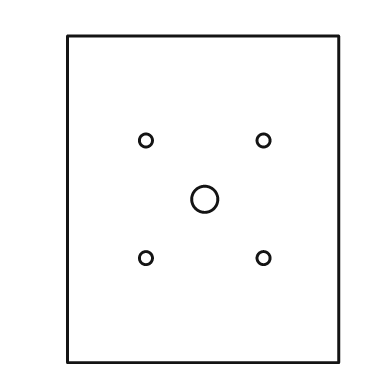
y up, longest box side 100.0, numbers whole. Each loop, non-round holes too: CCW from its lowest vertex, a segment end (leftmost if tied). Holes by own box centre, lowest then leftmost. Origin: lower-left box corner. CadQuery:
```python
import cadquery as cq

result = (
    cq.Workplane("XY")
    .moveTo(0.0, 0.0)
    .lineTo(83.0, 0.0)
    .lineTo(83.0, 100.0)
    .lineTo(0.0, 100.0)
    .close()
    .moveTo(24.0, 32.0)
    .circle(2.0)
    .moveTo(60.0, 32.0)
    .circle(2.0)
    .moveTo(42.0, 50.0)
    .circle(4.0)
    .moveTo(24.0, 68.0)
    .circle(2.0)
    .moveTo(60.0, 68.0)
    .circle(2.0)
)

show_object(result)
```